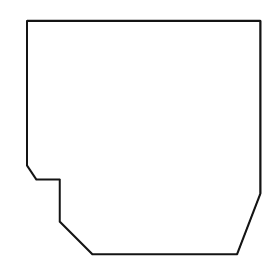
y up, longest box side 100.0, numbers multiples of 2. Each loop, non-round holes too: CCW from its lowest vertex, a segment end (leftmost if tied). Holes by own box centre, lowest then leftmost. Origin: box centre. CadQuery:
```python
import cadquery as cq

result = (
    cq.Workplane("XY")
    .moveTo(-22.0, -50.0)
    .lineTo(40.0, -50.0)
    .lineTo(50.0, -24.0)
    .lineTo(50.0, 50.0)
    .lineTo(-50.0, 50.0)
    .lineTo(-50.0, -12.0)
    .lineTo(-46.0, -18.0)
    .lineTo(-36.0, -18.0)
    .lineTo(-36.0, -36.0)
    .close()
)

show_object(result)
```